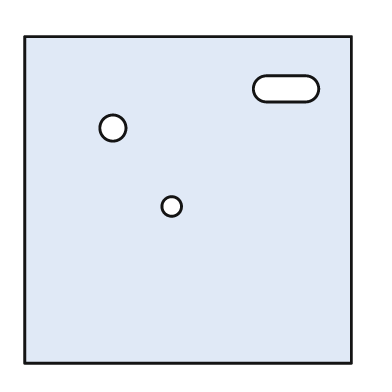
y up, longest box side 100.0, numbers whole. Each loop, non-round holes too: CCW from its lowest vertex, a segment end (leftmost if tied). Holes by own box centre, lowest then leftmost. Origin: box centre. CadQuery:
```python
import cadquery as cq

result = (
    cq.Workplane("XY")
    .moveTo(-50.0, -50.0)
    .lineTo(50.0, -50.0)
    .lineTo(50.0, 50.0)
    .lineTo(-50.0, 50.0)
    .close()
    .moveTo(-5.0, -2.0)
    .circle(3.0)
    .moveTo(-23.0, 22.0)
    .circle(4.0)
    .moveTo(24.0, 30.0)
    .lineTo(36.0, 30.0)
    .threePointArc((40.0, 34.0), (36.0, 38.0))
    .lineTo(24.0, 38.0)
    .threePointArc((20.0, 34.0), (24.0, 30.0))
    .close()
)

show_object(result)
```